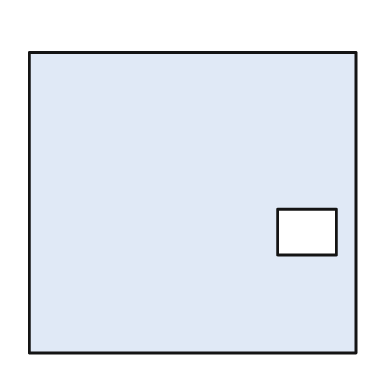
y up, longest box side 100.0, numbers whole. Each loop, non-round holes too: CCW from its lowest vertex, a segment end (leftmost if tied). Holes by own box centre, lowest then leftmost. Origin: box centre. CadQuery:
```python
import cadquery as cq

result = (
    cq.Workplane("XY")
    .moveTo(-50.0, -46.0)
    .lineTo(50.0, -46.0)
    .lineTo(50.0, 46.0)
    .lineTo(-50.0, 46.0)
    .close()
    .moveTo(26.0, -16.0)
    .lineTo(44.0, -16.0)
    .lineTo(44.0, -2.0)
    .lineTo(26.0, -2.0)
    .close()
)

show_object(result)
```